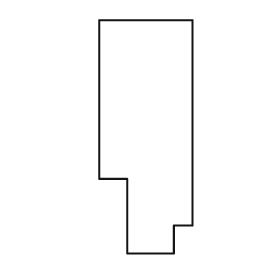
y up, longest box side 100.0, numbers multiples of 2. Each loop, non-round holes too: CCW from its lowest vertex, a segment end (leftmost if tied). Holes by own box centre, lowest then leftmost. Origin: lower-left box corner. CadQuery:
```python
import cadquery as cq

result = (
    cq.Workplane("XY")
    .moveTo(12.0, 0.0)
    .lineTo(32.0, 0.0)
    .lineTo(32.0, 12.0)
    .lineTo(40.0, 12.0)
    .lineTo(40.0, 100.0)
    .lineTo(0.0, 100.0)
    .lineTo(0.0, 32.0)
    .lineTo(12.0, 32.0)
    .close()
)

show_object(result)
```